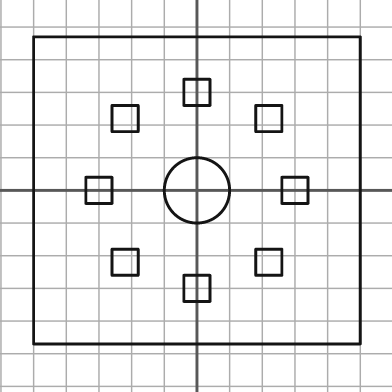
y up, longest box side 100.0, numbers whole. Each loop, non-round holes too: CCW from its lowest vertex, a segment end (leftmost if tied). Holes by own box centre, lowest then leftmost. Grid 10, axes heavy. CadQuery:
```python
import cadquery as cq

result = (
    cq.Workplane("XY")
    .moveTo(-50.0, -47.0)
    .lineTo(50.0, -47.0)
    .lineTo(50.0, 47.0)
    .lineTo(-50.0, 47.0)
    .close()
    .moveTo(-4.0, -34.0)
    .lineTo(4.0, -34.0)
    .lineTo(4.0, -26.0)
    .lineTo(-4.0, -26.0)
    .close()
    .moveTo(-26.0, -26.0)
    .lineTo(-18.0, -26.0)
    .lineTo(-18.0, -18.0)
    .lineTo(-26.0, -18.0)
    .close()
    .moveTo(18.0, -26.0)
    .lineTo(26.0, -26.0)
    .lineTo(26.0, -18.0)
    .lineTo(18.0, -18.0)
    .close()
    .moveTo(-34.0, -4.0)
    .lineTo(-26.0, -4.0)
    .lineTo(-26.0, 4.0)
    .lineTo(-34.0, 4.0)
    .close()
    .moveTo(0.0, 0.0)
    .circle(10.0)
    .moveTo(26.0, -4.0)
    .lineTo(34.0, -4.0)
    .lineTo(34.0, 4.0)
    .lineTo(26.0, 4.0)
    .close()
    .moveTo(-26.0, 18.0)
    .lineTo(-18.0, 18.0)
    .lineTo(-18.0, 26.0)
    .lineTo(-26.0, 26.0)
    .close()
    .moveTo(18.0, 18.0)
    .lineTo(26.0, 18.0)
    .lineTo(26.0, 26.0)
    .lineTo(18.0, 26.0)
    .close()
    .moveTo(-4.0, 26.0)
    .lineTo(4.0, 26.0)
    .lineTo(4.0, 34.0)
    .lineTo(-4.0, 34.0)
    .close()
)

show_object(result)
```